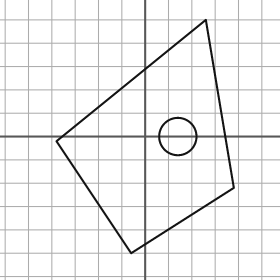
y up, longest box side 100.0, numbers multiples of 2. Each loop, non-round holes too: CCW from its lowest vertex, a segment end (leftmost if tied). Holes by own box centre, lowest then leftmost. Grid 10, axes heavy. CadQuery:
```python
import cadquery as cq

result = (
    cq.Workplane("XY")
    .moveTo(-6.0, -50.0)
    .lineTo(38.0, -22.0)
    .lineTo(26.0, 50.0)
    .lineTo(-38.0, -2.0)
    .close()
    .moveTo(14.0, 0.0)
    .circle(8.0)
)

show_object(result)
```